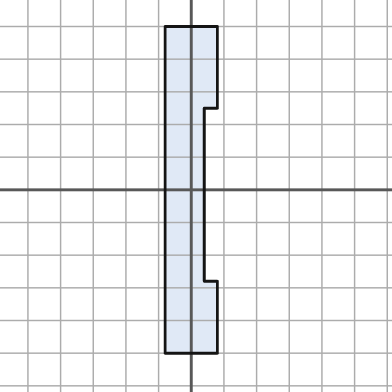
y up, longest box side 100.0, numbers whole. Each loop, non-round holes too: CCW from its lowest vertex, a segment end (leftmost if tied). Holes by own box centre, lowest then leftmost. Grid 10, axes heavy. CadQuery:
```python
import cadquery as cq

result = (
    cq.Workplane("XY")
    .moveTo(-8.0, -50.0)
    .lineTo(8.0, -50.0)
    .lineTo(8.0, -28.0)
    .lineTo(4.0, -28.0)
    .lineTo(4.0, 25.0)
    .lineTo(8.0, 25.0)
    .lineTo(8.0, 50.0)
    .lineTo(-8.0, 50.0)
    .close()
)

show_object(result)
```